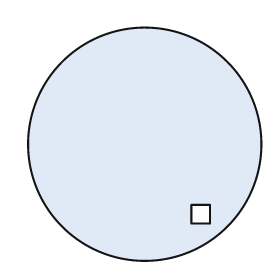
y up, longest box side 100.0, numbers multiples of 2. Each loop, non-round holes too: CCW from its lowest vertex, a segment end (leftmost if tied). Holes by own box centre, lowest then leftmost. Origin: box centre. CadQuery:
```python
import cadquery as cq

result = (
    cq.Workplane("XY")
    .moveTo(0.0, 0.0)
    .circle(50.0)
    .moveTo(20.0, -34.0)
    .lineTo(28.0, -34.0)
    .lineTo(28.0, -26.0)
    .lineTo(20.0, -26.0)
    .close()
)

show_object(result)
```